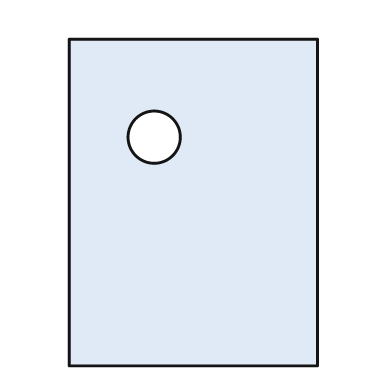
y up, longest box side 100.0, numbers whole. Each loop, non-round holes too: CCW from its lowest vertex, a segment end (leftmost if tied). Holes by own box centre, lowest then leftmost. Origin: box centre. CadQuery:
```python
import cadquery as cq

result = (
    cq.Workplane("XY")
    .moveTo(-38.0, -50.0)
    .lineTo(38.0, -50.0)
    .lineTo(38.0, 50.0)
    .lineTo(-38.0, 50.0)
    .close()
    .moveTo(-12.0, 20.0)
    .circle(8.0)
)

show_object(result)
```